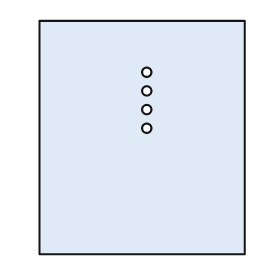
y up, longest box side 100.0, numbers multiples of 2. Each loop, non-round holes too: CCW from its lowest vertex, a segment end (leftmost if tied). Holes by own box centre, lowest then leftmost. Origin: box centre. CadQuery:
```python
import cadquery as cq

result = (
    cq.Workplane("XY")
    .moveTo(-44.0, -50.0)
    .lineTo(44.0, -50.0)
    .lineTo(44.0, 50.0)
    .lineTo(-44.0, 50.0)
    .close()
    .moveTo(2.0, 4.0)
    .circle(2.0)
    .moveTo(2.0, 12.0)
    .circle(2.0)
    .moveTo(2.0, 20.0)
    .circle(2.0)
    .moveTo(2.0, 28.0)
    .circle(2.0)
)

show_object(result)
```